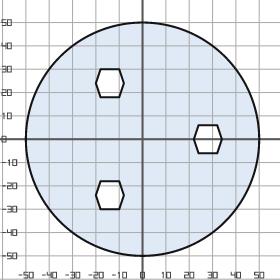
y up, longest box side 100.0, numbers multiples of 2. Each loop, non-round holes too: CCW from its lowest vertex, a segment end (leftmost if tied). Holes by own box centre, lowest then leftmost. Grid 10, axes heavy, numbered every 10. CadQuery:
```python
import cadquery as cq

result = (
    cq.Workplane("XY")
    .moveTo(0.0, 0.0)
    .circle(50.0)
    .moveTo(-18.0, -30.0)
    .lineTo(-10.0, -30.0)
    .lineTo(-8.0, -24.0)
    .lineTo(-10.0, -18.0)
    .lineTo(-18.0, -18.0)
    .lineTo(-20.0, -24.0)
    .close()
    .moveTo(24.0, -6.0)
    .lineTo(32.0, -6.0)
    .lineTo(34.0, 0.0)
    .lineTo(32.0, 6.0)
    .lineTo(24.0, 6.0)
    .lineTo(22.0, 0.0)
    .close()
    .moveTo(-18.0, 18.0)
    .lineTo(-10.0, 18.0)
    .lineTo(-8.0, 24.0)
    .lineTo(-10.0, 30.0)
    .lineTo(-18.0, 30.0)
    .lineTo(-20.0, 24.0)
    .close()
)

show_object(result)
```